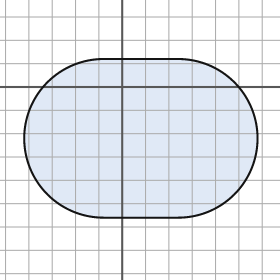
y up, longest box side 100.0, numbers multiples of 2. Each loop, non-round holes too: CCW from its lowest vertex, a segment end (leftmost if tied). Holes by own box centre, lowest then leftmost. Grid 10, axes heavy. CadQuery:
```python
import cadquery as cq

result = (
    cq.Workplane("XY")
    .moveTo(-8.0, -56.0)
    .lineTo(24.0, -56.0)
    .threePointArc((58.0, -22.0), (24.0, 12.0))
    .lineTo(-8.0, 12.0)
    .threePointArc((-42.0, -22.0), (-8.0, -56.0))
    .close()
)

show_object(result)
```